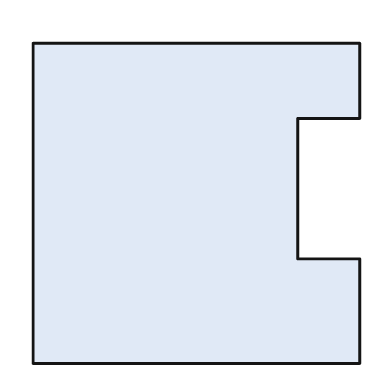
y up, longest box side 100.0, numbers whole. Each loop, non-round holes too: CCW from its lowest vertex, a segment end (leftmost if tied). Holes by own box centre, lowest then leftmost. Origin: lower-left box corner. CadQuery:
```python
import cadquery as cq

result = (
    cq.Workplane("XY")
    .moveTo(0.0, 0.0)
    .lineTo(100.0, 0.0)
    .lineTo(100.0, 32.0)
    .lineTo(81.0, 32.0)
    .lineTo(81.0, 75.0)
    .lineTo(100.0, 75.0)
    .lineTo(100.0, 98.0)
    .lineTo(0.0, 98.0)
    .close()
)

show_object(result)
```